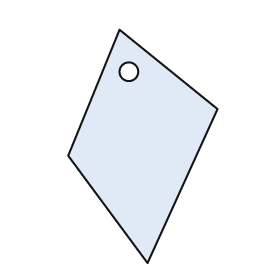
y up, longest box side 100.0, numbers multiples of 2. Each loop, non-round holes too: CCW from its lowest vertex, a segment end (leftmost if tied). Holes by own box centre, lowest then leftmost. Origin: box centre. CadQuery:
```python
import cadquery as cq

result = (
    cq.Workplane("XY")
    .moveTo(2.0, -50.0)
    .lineTo(32.0, 16.0)
    .lineTo(-10.0, 50.0)
    .lineTo(-32.0, -4.0)
    .close()
    .moveTo(-6.0, 32.0)
    .circle(4.0)
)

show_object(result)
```